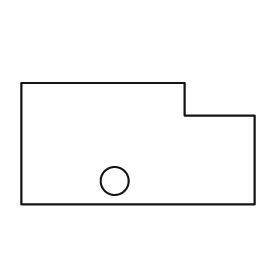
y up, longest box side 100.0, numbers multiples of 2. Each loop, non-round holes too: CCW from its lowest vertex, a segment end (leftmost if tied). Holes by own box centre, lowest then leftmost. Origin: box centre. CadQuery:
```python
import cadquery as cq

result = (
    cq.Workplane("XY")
    .moveTo(-50.0, -26.0)
    .lineTo(50.0, -26.0)
    .lineTo(50.0, 12.0)
    .lineTo(20.0, 12.0)
    .lineTo(20.0, 26.0)
    .lineTo(-50.0, 26.0)
    .close()
    .moveTo(-10.0, -16.0)
    .circle(6.0)
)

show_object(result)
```